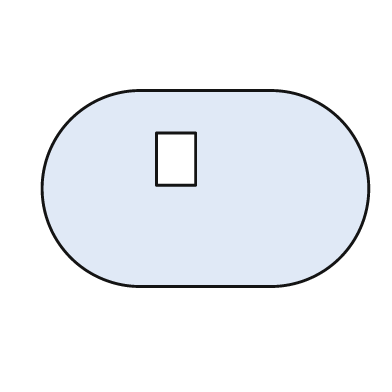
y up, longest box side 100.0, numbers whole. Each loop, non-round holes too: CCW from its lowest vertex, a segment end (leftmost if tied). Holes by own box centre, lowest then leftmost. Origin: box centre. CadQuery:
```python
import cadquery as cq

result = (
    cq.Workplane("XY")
    .moveTo(-20.0, -30.0)
    .lineTo(20.0, -30.0)
    .threePointArc((50.0, 0.0), (20.0, 30.0))
    .lineTo(-20.0, 30.0)
    .threePointArc((-50.0, 0.0), (-20.0, -30.0))
    .close()
    .moveTo(-15.0, 1.0)
    .lineTo(-3.0, 1.0)
    .lineTo(-3.0, 17.0)
    .lineTo(-15.0, 17.0)
    .close()
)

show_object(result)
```